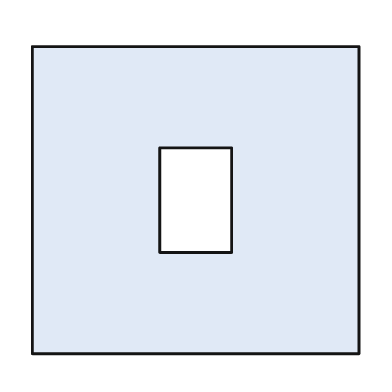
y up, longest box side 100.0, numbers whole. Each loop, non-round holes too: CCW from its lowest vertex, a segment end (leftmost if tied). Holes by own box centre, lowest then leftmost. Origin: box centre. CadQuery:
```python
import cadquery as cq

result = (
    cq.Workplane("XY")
    .moveTo(-50.0, -47.0)
    .lineTo(50.0, -47.0)
    .lineTo(50.0, 47.0)
    .lineTo(-50.0, 47.0)
    .close()
    .moveTo(-11.0, -16.0)
    .lineTo(11.0, -16.0)
    .lineTo(11.0, 16.0)
    .lineTo(-11.0, 16.0)
    .close()
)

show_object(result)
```